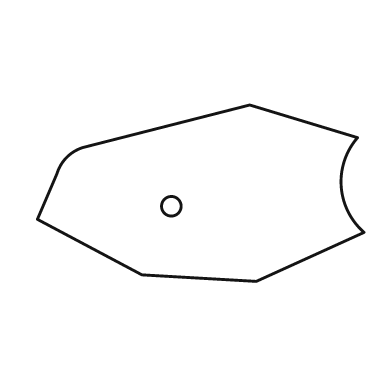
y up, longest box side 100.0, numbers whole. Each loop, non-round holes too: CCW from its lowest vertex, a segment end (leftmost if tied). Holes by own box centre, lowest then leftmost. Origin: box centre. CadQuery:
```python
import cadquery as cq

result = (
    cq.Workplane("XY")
    .moveTo(17.0, -27.0)
    .lineTo(50.0, -12.0)
    .threePointArc((43.0, 2.0), (48.0, 17.0))
    .lineTo(15.0, 27.0)
    .lineTo(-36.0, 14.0)
    .threePointArc((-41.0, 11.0), (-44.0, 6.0))
    .lineTo(-50.0, -8.0)
    .lineTo(-18.0, -25.0)
    .close()
    .moveTo(-9.0, -4.0)
    .circle(3.0)
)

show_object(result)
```